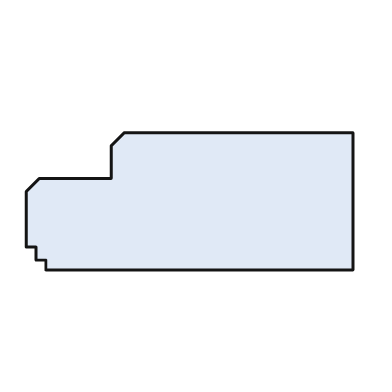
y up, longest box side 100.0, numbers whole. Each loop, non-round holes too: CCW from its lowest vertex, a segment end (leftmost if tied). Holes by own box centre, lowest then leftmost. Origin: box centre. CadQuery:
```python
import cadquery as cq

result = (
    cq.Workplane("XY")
    .moveTo(-44.0, -21.0)
    .lineTo(50.0, -21.0)
    .lineTo(50.0, 21.0)
    .lineTo(-20.0, 21.0)
    .lineTo(-24.0, 17.0)
    .lineTo(-24.0, 7.0)
    .lineTo(-46.0, 7.0)
    .lineTo(-50.0, 3.0)
    .lineTo(-50.0, -14.0)
    .lineTo(-47.0, -14.0)
    .lineTo(-47.0, -18.0)
    .lineTo(-44.0, -18.0)
    .close()
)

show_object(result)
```